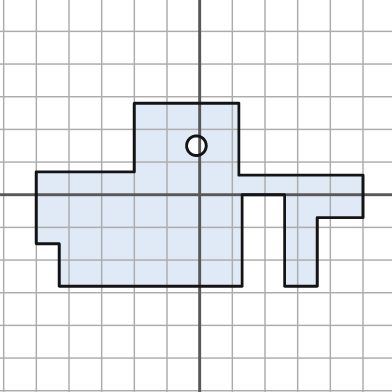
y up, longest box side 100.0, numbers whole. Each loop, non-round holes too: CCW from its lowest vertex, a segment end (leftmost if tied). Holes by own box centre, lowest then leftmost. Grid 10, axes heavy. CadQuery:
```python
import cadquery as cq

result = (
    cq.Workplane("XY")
    .moveTo(-43.0, -28.0)
    .lineTo(13.0, -28.0)
    .lineTo(13.0, 0.0)
    .lineTo(26.0, 0.0)
    .lineTo(26.0, -28.0)
    .lineTo(36.0, -28.0)
    .lineTo(36.0, -7.0)
    .lineTo(50.0, -7.0)
    .lineTo(50.0, 6.0)
    .lineTo(12.0, 6.0)
    .lineTo(12.0, 28.0)
    .lineTo(-20.0, 28.0)
    .lineTo(-20.0, 7.0)
    .lineTo(-50.0, 7.0)
    .lineTo(-50.0, -15.0)
    .lineTo(-43.0, -15.0)
    .close()
    .moveTo(-1.0, 15.0)
    .circle(3.0)
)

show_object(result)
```